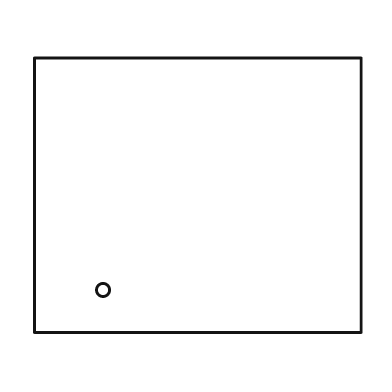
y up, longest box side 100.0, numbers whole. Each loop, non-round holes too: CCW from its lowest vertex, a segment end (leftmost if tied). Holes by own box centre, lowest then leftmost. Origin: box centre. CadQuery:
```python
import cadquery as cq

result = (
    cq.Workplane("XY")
    .moveTo(-50.0, -42.0)
    .lineTo(50.0, -42.0)
    .lineTo(50.0, 42.0)
    .lineTo(-50.0, 42.0)
    .close()
    .moveTo(-29.0, -29.0)
    .circle(2.0)
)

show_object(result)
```